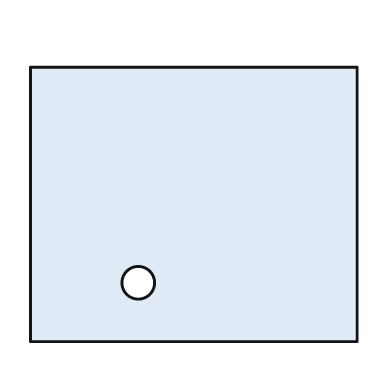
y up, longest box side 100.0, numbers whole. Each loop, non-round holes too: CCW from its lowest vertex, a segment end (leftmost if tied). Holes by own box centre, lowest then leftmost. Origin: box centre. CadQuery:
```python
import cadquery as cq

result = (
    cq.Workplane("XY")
    .moveTo(-50.0, -42.0)
    .lineTo(50.0, -42.0)
    .lineTo(50.0, 42.0)
    .lineTo(-50.0, 42.0)
    .close()
    .moveTo(-17.0, -24.0)
    .circle(5.0)
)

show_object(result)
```